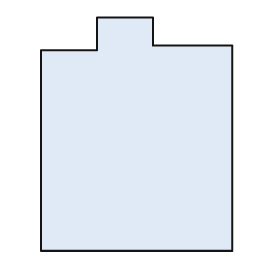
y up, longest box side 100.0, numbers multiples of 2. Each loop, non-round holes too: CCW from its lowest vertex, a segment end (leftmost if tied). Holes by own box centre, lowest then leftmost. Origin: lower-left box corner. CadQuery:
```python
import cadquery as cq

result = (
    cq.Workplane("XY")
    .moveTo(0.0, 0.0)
    .lineTo(82.0, 0.0)
    .lineTo(82.0, 88.0)
    .lineTo(48.0, 88.0)
    .lineTo(48.0, 100.0)
    .lineTo(24.0, 100.0)
    .lineTo(24.0, 86.0)
    .lineTo(0.0, 86.0)
    .close()
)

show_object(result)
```